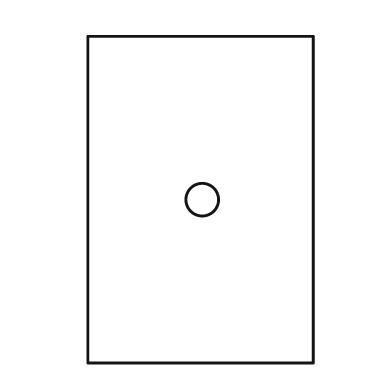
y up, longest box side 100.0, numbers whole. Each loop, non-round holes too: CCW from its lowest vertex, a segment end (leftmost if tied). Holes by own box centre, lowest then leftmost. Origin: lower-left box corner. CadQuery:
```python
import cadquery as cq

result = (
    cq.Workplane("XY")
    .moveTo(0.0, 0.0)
    .lineTo(69.0, 0.0)
    .lineTo(69.0, 100.0)
    .lineTo(0.0, 100.0)
    .close()
    .moveTo(35.0, 50.0)
    .circle(5.0)
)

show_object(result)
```